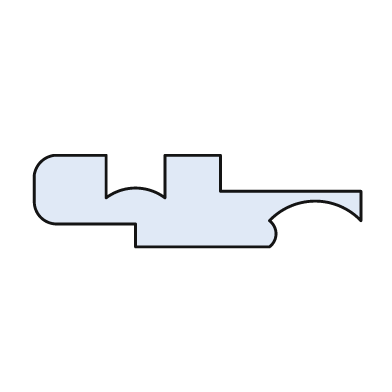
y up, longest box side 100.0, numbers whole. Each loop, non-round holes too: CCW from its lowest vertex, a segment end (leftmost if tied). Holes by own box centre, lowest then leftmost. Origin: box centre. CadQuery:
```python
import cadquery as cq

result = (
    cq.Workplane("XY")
    .moveTo(-19.0, -14.0)
    .lineTo(22.0, -14.0)
    .threePointArc((24.0, -10.0), (22.0, -6.0))
    .threePointArc((36.0, 0.0), (50.0, -6.0))
    .lineTo(50.0, 3.0)
    .lineTo(7.0, 3.0)
    .lineTo(7.0, 14.0)
    .lineTo(-10.0, 14.0)
    .lineTo(-10.0, 1.0)
    .threePointArc((-19.0, 4.0), (-28.0, 1.0))
    .lineTo(-28.0, 14.0)
    .lineTo(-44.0, 14.0)
    .threePointArc((-48.0, 12.0), (-50.0, 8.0))
    .lineTo(-50.0, 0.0)
    .threePointArc((-48.0, -5.0), (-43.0, -7.0))
    .lineTo(-19.0, -7.0)
    .close()
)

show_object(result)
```